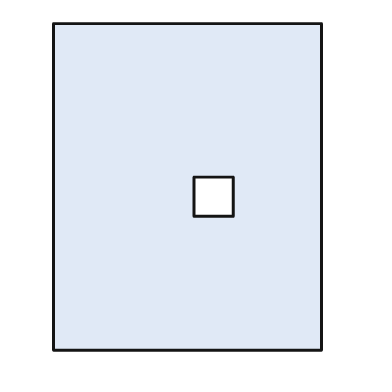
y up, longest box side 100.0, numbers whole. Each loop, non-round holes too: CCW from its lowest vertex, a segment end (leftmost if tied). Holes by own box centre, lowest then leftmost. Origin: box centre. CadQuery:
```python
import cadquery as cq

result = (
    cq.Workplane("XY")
    .moveTo(-41.0, -50.0)
    .lineTo(41.0, -50.0)
    .lineTo(41.0, 50.0)
    .lineTo(-41.0, 50.0)
    .close()
    .moveTo(2.0, -9.0)
    .lineTo(14.0, -9.0)
    .lineTo(14.0, 3.0)
    .lineTo(2.0, 3.0)
    .close()
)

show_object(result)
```